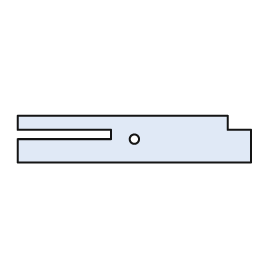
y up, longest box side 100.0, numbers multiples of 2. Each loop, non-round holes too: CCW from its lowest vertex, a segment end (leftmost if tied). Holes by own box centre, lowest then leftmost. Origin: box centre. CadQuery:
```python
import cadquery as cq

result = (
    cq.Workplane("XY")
    .moveTo(-50.0, -10.0)
    .lineTo(50.0, -10.0)
    .lineTo(50.0, 4.0)
    .lineTo(40.0, 4.0)
    .lineTo(40.0, 10.0)
    .lineTo(-50.0, 10.0)
    .lineTo(-50.0, 4.0)
    .lineTo(-10.0, 4.0)
    .lineTo(-10.0, 0.0)
    .lineTo(-50.0, 0.0)
    .close()
    .moveTo(0.0, 0.0)
    .circle(2.0)
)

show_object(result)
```